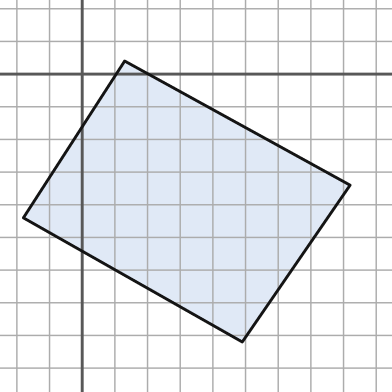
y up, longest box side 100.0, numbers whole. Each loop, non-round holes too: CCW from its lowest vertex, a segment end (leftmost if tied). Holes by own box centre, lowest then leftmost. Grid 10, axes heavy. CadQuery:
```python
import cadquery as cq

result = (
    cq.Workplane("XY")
    .moveTo(49.0, -82.0)
    .lineTo(82.0, -34.0)
    .lineTo(13.0, 4.0)
    .lineTo(-18.0, -44.0)
    .close()
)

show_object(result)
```